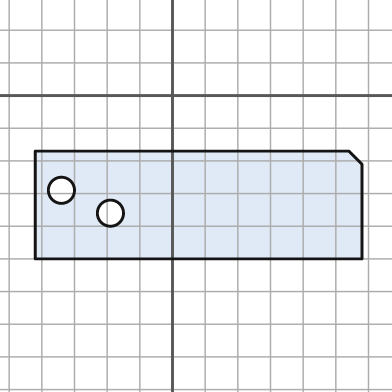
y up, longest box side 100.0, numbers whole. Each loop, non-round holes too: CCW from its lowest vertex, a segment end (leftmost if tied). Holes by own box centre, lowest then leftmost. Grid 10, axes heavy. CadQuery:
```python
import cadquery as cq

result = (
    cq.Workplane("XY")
    .moveTo(-42.0, -50.0)
    .lineTo(58.0, -50.0)
    .lineTo(58.0, -21.0)
    .lineTo(54.0, -17.0)
    .lineTo(-42.0, -17.0)
    .close()
    .moveTo(-19.0, -36.0)
    .circle(4.0)
    .moveTo(-34.0, -29.0)
    .circle(4.0)
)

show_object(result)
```